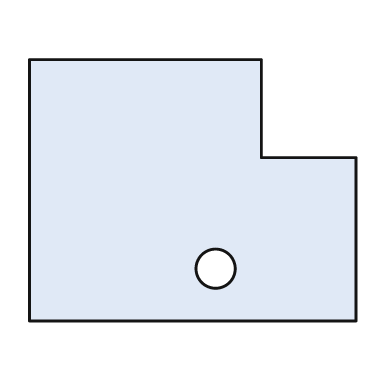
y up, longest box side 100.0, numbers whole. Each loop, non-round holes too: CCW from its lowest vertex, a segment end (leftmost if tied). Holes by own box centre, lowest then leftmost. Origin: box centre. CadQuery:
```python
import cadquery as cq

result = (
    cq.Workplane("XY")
    .moveTo(-50.0, -40.0)
    .lineTo(50.0, -40.0)
    .lineTo(50.0, 10.0)
    .lineTo(21.0, 10.0)
    .lineTo(21.0, 40.0)
    .lineTo(-50.0, 40.0)
    .close()
    .moveTo(7.0, -24.0)
    .circle(6.0)
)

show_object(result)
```